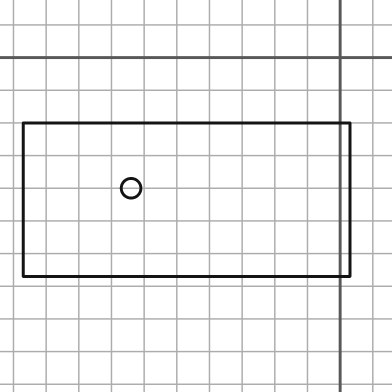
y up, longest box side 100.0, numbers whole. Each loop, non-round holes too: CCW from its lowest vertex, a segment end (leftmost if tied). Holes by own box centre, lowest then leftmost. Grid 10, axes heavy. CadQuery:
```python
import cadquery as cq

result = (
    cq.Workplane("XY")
    .moveTo(-97.0, -67.0)
    .lineTo(3.0, -67.0)
    .lineTo(3.0, -20.0)
    .lineTo(-97.0, -20.0)
    .close()
    .moveTo(-64.0, -40.0)
    .circle(3.0)
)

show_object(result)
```